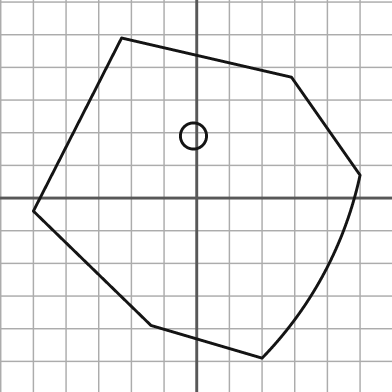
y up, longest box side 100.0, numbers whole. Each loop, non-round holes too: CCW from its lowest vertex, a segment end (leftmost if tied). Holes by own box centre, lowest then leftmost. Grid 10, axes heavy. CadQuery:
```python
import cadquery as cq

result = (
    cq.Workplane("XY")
    .moveTo(20.0, -49.0)
    .threePointArc((39.0, -23.0), (50.0, 7.0))
    .lineTo(29.0, 37.0)
    .lineTo(-23.0, 49.0)
    .lineTo(-50.0, -4.0)
    .lineTo(-14.0, -39.0)
    .close()
    .moveTo(-1.0, 19.0)
    .circle(4.0)
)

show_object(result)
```